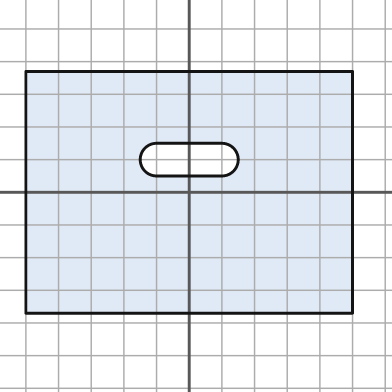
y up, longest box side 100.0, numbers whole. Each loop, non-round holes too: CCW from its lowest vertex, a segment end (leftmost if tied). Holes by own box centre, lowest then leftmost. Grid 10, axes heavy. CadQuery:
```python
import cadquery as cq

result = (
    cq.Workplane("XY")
    .moveTo(-50.0, -37.0)
    .lineTo(50.0, -37.0)
    .lineTo(50.0, 37.0)
    .lineTo(-50.0, 37.0)
    .close()
    .moveTo(-10.0, 5.0)
    .lineTo(10.0, 5.0)
    .threePointArc((15.0, 10.0), (10.0, 15.0))
    .lineTo(-10.0, 15.0)
    .threePointArc((-15.0, 10.0), (-10.0, 5.0))
    .close()
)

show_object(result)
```